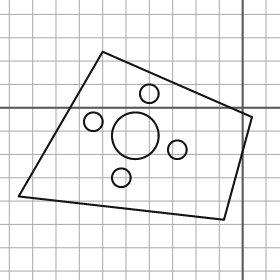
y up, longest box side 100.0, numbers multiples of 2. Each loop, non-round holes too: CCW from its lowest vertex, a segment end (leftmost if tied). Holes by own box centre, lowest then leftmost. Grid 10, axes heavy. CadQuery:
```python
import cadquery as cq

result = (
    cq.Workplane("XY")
    .moveTo(-8.0, -48.0)
    .lineTo(4.0, -4.0)
    .lineTo(-60.0, 24.0)
    .lineTo(-96.0, -38.0)
    .close()
    .moveTo(-52.0, -30.0)
    .circle(4.0)
    .moveTo(-28.0, -18.0)
    .circle(4.0)
    .moveTo(-46.0, -12.0)
    .circle(10.0)
    .moveTo(-64.0, -6.0)
    .circle(4.0)
    .moveTo(-40.0, 6.0)
    .circle(4.0)
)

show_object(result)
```